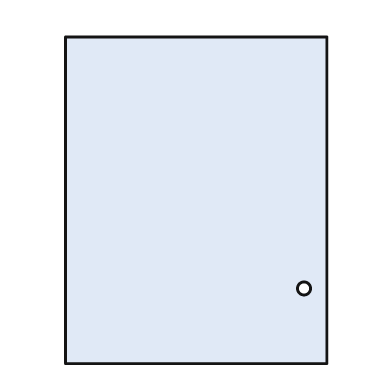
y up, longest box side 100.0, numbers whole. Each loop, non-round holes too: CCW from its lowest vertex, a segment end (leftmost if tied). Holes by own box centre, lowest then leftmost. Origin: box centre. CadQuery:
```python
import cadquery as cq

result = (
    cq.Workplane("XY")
    .moveTo(-40.0, -50.0)
    .lineTo(40.0, -50.0)
    .lineTo(40.0, 50.0)
    .lineTo(-40.0, 50.0)
    .close()
    .moveTo(33.0, -27.0)
    .circle(2.0)
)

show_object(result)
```